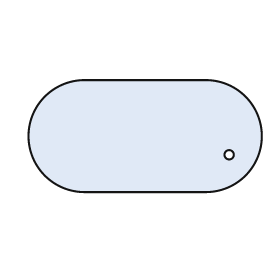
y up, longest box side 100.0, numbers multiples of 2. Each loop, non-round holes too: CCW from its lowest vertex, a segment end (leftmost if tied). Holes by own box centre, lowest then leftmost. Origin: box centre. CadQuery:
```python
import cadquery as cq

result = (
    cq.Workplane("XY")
    .moveTo(-26.0, -24.0)
    .lineTo(26.0, -24.0)
    .threePointArc((50.0, 0.0), (26.0, 24.0))
    .lineTo(-26.0, 24.0)
    .threePointArc((-50.0, 0.0), (-26.0, -24.0))
    .close()
    .moveTo(36.0, -8.0)
    .circle(2.0)
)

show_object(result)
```